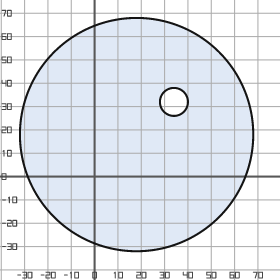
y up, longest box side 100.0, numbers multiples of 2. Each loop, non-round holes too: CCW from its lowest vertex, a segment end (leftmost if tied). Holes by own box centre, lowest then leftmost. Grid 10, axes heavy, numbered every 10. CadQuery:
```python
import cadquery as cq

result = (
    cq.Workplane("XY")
    .moveTo(18.0, 18.0)
    .circle(50.0)
    .moveTo(34.0, 32.0)
    .circle(6.0)
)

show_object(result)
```